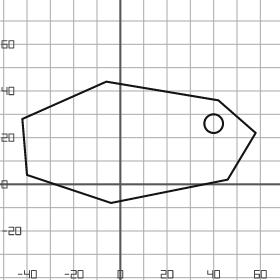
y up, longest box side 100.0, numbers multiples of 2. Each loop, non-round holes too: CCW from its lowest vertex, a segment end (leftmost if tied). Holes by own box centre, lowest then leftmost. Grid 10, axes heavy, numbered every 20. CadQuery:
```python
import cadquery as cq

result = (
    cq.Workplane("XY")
    .moveTo(-4.0, -8.0)
    .lineTo(46.0, 2.0)
    .lineTo(58.0, 22.0)
    .lineTo(42.0, 36.0)
    .lineTo(-6.0, 44.0)
    .lineTo(-42.0, 28.0)
    .lineTo(-40.0, 4.0)
    .close()
    .moveTo(40.0, 26.0)
    .circle(4.0)
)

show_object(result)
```